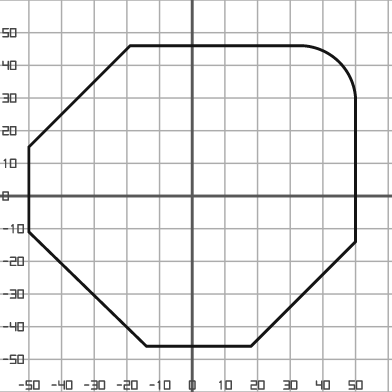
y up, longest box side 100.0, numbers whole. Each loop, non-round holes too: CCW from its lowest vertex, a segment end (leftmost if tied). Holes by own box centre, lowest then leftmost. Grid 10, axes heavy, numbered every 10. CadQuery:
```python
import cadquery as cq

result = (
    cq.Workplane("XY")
    .moveTo(-14.0, -46.0)
    .lineTo(18.0, -46.0)
    .lineTo(50.0, -14.0)
    .lineTo(50.0, 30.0)
    .threePointArc((45.0, 41.0), (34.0, 46.0))
    .lineTo(-19.0, 46.0)
    .lineTo(-50.0, 15.0)
    .lineTo(-50.0, -11.0)
    .close()
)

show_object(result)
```